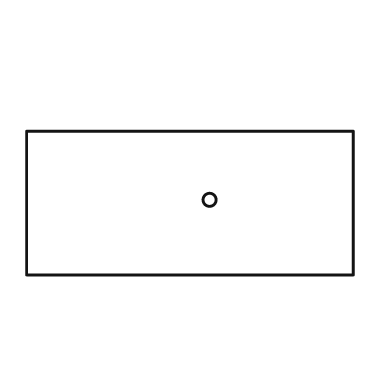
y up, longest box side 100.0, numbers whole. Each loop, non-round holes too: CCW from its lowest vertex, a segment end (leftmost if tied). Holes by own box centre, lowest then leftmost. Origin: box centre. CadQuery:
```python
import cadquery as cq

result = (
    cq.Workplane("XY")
    .moveTo(-50.0, -22.0)
    .lineTo(50.0, -22.0)
    .lineTo(50.0, 22.0)
    .lineTo(-50.0, 22.0)
    .close()
    .moveTo(6.0, 1.0)
    .circle(2.0)
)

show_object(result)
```